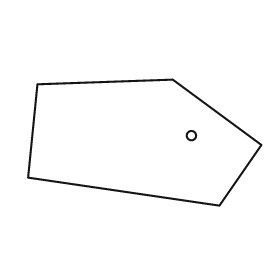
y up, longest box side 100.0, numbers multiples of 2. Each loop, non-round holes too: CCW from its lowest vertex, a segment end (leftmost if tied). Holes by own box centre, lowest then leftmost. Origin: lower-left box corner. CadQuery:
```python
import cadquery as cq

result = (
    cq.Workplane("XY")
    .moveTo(82.0, 0.0)
    .lineTo(100.0, 26.0)
    .lineTo(62.0, 54.0)
    .lineTo(4.0, 52.0)
    .lineTo(0.0, 12.0)
    .close()
    .moveTo(70.0, 30.0)
    .circle(2.0)
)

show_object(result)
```